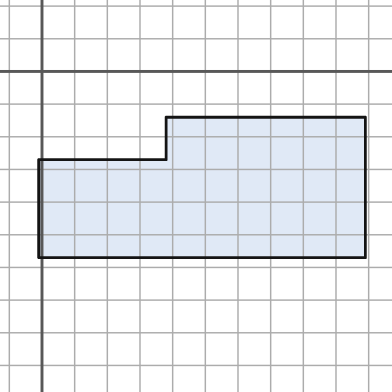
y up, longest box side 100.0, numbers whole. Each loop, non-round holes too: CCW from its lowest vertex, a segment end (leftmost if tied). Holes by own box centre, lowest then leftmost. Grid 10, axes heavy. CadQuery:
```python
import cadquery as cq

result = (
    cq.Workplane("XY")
    .moveTo(-1.0, -57.0)
    .lineTo(99.0, -57.0)
    .lineTo(99.0, -14.0)
    .lineTo(38.0, -14.0)
    .lineTo(38.0, -27.0)
    .lineTo(-1.0, -27.0)
    .close()
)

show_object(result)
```